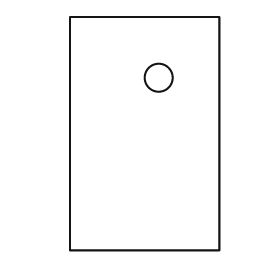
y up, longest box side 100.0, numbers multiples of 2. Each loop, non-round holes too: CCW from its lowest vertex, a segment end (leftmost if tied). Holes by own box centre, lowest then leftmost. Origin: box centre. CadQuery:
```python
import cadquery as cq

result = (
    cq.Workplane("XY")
    .moveTo(-32.0, -50.0)
    .lineTo(32.0, -50.0)
    .lineTo(32.0, 50.0)
    .lineTo(-32.0, 50.0)
    .close()
    .moveTo(6.0, 24.0)
    .circle(6.0)
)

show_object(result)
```